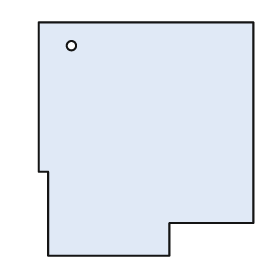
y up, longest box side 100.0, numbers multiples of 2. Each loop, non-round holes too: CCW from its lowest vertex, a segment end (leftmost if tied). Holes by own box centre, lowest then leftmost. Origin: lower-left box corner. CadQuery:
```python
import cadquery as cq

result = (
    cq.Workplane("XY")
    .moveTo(4.0, 0.0)
    .lineTo(56.0, 0.0)
    .lineTo(56.0, 14.0)
    .lineTo(92.0, 14.0)
    .lineTo(92.0, 100.0)
    .lineTo(0.0, 100.0)
    .lineTo(0.0, 36.0)
    .lineTo(4.0, 36.0)
    .close()
    .moveTo(14.0, 90.0)
    .circle(2.0)
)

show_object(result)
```